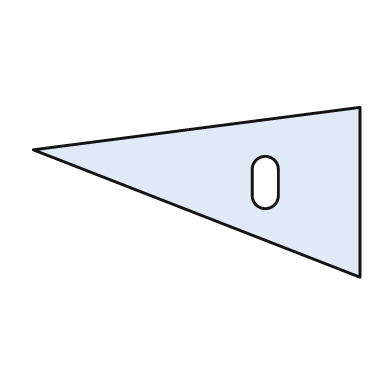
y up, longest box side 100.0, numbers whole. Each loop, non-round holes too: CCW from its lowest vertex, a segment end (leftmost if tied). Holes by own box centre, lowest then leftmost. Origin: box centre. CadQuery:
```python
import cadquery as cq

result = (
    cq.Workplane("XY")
    .moveTo(50.0, -26.0)
    .lineTo(50.0, 26.0)
    .lineTo(-50.0, 13.0)
    .close()
    .moveTo(17.0, -1.0)
    .threePointArc((21.0, -5.0), (25.0, -1.0))
    .lineTo(25.0, 7.0)
    .threePointArc((21.0, 11.0), (17.0, 7.0))
    .close()
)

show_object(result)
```